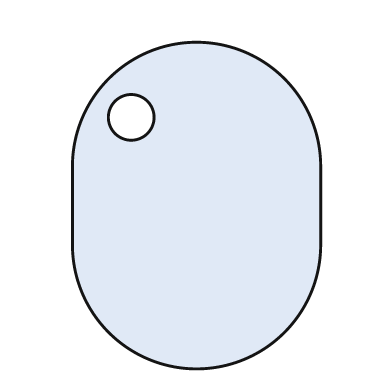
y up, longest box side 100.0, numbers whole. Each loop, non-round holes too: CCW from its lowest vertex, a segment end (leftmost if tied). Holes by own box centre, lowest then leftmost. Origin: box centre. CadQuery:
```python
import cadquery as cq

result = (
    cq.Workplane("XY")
    .moveTo(-38.0, -12.0)
    .threePointArc((0.0, -50.0), (38.0, -12.0))
    .lineTo(38.0, 12.0)
    .threePointArc((0.0, 50.0), (-38.0, 12.0))
    .close()
    .moveTo(-20.0, 27.0)
    .circle(7.0)
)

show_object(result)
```